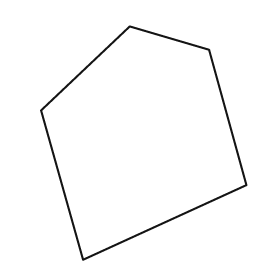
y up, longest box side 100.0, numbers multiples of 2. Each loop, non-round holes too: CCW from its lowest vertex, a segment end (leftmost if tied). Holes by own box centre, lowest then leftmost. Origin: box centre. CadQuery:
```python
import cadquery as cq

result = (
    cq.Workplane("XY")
    .moveTo(-26.0, -50.0)
    .lineTo(44.0, -18.0)
    .lineTo(28.0, 40.0)
    .lineTo(-6.0, 50.0)
    .lineTo(-44.0, 14.0)
    .close()
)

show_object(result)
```